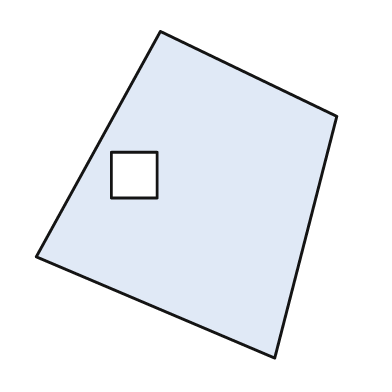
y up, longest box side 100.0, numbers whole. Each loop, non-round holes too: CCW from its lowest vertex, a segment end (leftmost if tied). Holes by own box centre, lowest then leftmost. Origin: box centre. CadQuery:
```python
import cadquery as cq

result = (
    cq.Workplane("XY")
    .moveTo(27.0, -50.0)
    .lineTo(46.0, 24.0)
    .lineTo(-8.0, 50.0)
    .lineTo(-46.0, -19.0)
    .close()
    .moveTo(-23.0, -1.0)
    .lineTo(-9.0, -1.0)
    .lineTo(-9.0, 13.0)
    .lineTo(-23.0, 13.0)
    .close()
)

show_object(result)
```